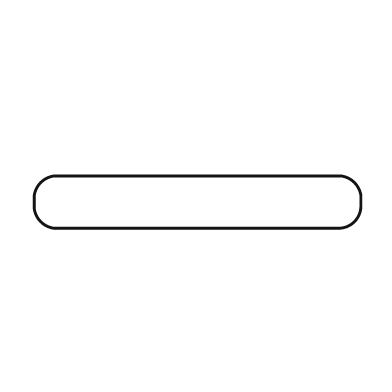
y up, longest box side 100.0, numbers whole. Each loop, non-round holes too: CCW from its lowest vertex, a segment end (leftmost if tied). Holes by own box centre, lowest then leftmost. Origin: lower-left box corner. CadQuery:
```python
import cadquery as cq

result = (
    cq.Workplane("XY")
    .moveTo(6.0, 0.0)
    .lineTo(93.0, 0.0)
    .threePointArc((98.0, 2.0), (100.0, 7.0))
    .lineTo(100.0, 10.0)
    .threePointArc((98.0, 14.0), (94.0, 16.0))
    .lineTo(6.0, 16.0)
    .threePointArc((2.0, 14.0), (0.0, 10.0))
    .lineTo(0.0, 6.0)
    .threePointArc((2.0, 2.0), (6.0, 0.0))
    .close()
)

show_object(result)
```